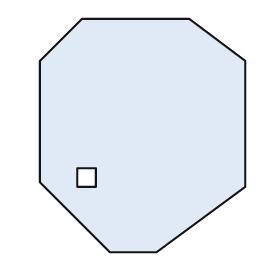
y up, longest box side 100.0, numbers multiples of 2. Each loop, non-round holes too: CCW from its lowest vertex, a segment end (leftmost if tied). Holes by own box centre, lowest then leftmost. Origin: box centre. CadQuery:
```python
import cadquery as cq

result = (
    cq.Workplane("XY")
    .moveTo(-14.0, -50.0)
    .lineTo(6.0, -50.0)
    .lineTo(44.0, -22.0)
    .lineTo(44.0, 32.0)
    .lineTo(20.0, 50.0)
    .lineTo(-26.0, 50.0)
    .lineTo(-44.0, 32.0)
    .lineTo(-44.0, -20.0)
    .close()
    .moveTo(-28.0, -22.0)
    .lineTo(-20.0, -22.0)
    .lineTo(-20.0, -14.0)
    .lineTo(-28.0, -14.0)
    .close()
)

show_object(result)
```